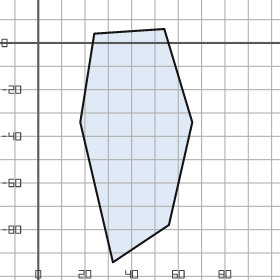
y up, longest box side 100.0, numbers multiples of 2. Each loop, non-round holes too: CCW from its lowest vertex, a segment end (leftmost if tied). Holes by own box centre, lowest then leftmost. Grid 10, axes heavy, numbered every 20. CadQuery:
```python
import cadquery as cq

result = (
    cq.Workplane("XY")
    .moveTo(32.0, -94.0)
    .lineTo(56.0, -78.0)
    .lineTo(66.0, -34.0)
    .lineTo(54.0, 6.0)
    .lineTo(24.0, 4.0)
    .lineTo(18.0, -34.0)
    .close()
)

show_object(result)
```